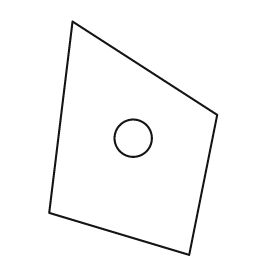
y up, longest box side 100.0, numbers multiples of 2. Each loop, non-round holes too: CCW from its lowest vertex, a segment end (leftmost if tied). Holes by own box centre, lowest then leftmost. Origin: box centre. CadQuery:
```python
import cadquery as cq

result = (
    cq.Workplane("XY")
    .moveTo(24.0, -50.0)
    .lineTo(36.0, 10.0)
    .lineTo(-26.0, 50.0)
    .lineTo(-36.0, -32.0)
    .close()
    .moveTo(0.0, 0.0)
    .circle(8.0)
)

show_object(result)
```